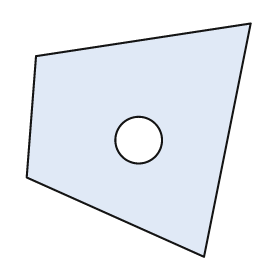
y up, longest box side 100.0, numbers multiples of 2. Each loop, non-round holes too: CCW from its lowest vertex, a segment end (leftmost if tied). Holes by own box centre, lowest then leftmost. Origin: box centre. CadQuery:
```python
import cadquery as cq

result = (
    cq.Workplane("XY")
    .moveTo(28.0, -50.0)
    .lineTo(48.0, 50.0)
    .lineTo(-44.0, 36.0)
    .lineTo(-48.0, -16.0)
    .close()
    .moveTo(0.0, 0.0)
    .circle(10.0)
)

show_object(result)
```